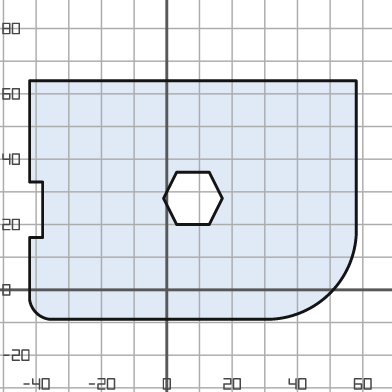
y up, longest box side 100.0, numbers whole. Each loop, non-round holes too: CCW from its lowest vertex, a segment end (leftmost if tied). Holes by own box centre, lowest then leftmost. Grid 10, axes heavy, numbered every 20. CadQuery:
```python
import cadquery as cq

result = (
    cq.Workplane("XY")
    .moveTo(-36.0, -9.0)
    .lineTo(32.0, -9.0)
    .threePointArc((50.0, -1.0), (58.0, 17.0))
    .lineTo(58.0, 64.0)
    .lineTo(-42.0, 64.0)
    .lineTo(-42.0, 33.0)
    .lineTo(-38.0, 33.0)
    .lineTo(-38.0, 16.0)
    .lineTo(-42.0, 16.0)
    .lineTo(-42.0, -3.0)
    .threePointArc((-40.0, -7.0), (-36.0, -9.0))
    .close()
    .moveTo(3.0, 20.0)
    .lineTo(13.0, 20.0)
    .lineTo(17.0, 28.0)
    .lineTo(13.0, 36.0)
    .lineTo(3.0, 36.0)
    .lineTo(-1.0, 28.0)
    .close()
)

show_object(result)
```